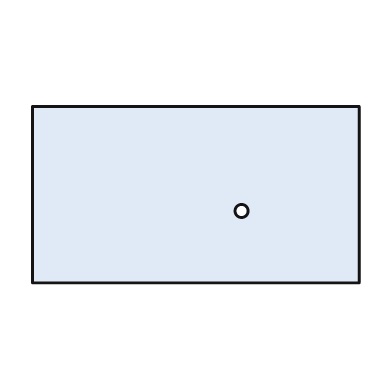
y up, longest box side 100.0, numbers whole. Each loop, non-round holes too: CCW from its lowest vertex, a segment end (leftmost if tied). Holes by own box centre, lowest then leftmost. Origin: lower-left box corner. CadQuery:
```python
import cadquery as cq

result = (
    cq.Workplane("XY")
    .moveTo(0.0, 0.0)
    .lineTo(100.0, 0.0)
    .lineTo(100.0, 54.0)
    .lineTo(0.0, 54.0)
    .close()
    .moveTo(64.0, 22.0)
    .circle(2.0)
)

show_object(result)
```